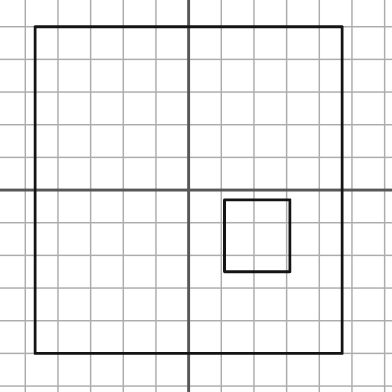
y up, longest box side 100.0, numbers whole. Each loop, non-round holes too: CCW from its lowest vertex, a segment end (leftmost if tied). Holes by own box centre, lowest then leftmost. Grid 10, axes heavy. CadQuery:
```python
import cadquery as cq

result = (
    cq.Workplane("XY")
    .moveTo(-47.0, -50.0)
    .lineTo(47.0, -50.0)
    .lineTo(47.0, 50.0)
    .lineTo(-47.0, 50.0)
    .close()
    .moveTo(11.0, -25.0)
    .lineTo(31.0, -25.0)
    .lineTo(31.0, -3.0)
    .lineTo(11.0, -3.0)
    .close()
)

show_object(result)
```